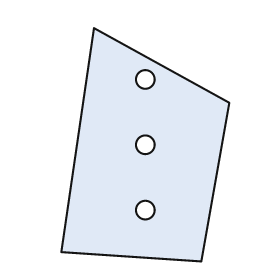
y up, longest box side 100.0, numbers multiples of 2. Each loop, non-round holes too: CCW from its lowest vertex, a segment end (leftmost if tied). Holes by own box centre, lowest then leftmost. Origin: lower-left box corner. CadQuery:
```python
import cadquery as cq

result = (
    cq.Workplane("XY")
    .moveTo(60.0, 0.0)
    .lineTo(72.0, 68.0)
    .lineTo(14.0, 100.0)
    .lineTo(0.0, 4.0)
    .close()
    .moveTo(36.0, 22.0)
    .circle(4.0)
    .moveTo(36.0, 50.0)
    .circle(4.0)
    .moveTo(36.0, 78.0)
    .circle(4.0)
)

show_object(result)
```